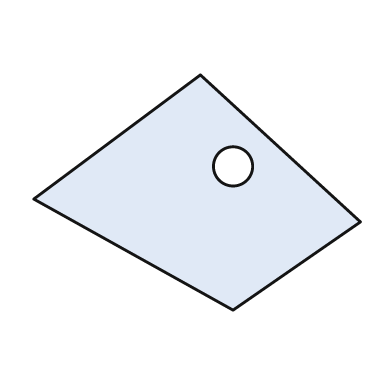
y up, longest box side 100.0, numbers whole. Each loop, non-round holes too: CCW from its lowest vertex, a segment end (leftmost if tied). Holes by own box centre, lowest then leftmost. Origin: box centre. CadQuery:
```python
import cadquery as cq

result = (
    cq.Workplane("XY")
    .moveTo(11.0, -36.0)
    .lineTo(50.0, -9.0)
    .lineTo(1.0, 36.0)
    .lineTo(-50.0, -2.0)
    .close()
    .moveTo(11.0, 8.0)
    .circle(6.0)
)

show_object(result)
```